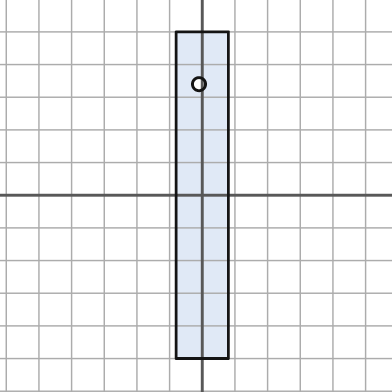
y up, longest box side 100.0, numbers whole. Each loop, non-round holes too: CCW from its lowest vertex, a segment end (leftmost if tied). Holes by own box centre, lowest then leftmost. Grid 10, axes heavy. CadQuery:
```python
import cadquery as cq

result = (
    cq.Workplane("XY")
    .moveTo(-8.0, -50.0)
    .lineTo(8.0, -50.0)
    .lineTo(8.0, 50.0)
    .lineTo(-8.0, 50.0)
    .close()
    .moveTo(-1.0, 34.0)
    .circle(2.0)
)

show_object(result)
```